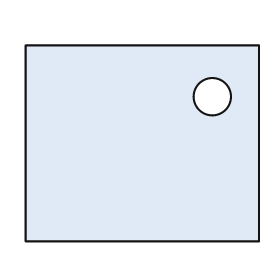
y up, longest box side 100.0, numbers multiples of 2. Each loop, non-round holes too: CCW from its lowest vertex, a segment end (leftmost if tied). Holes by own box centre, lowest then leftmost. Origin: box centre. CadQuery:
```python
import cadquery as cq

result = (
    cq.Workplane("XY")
    .moveTo(-50.0, -42.0)
    .lineTo(50.0, -42.0)
    .lineTo(50.0, 42.0)
    .lineTo(-50.0, 42.0)
    .close()
    .moveTo(30.0, 20.0)
    .circle(8.0)
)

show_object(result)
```